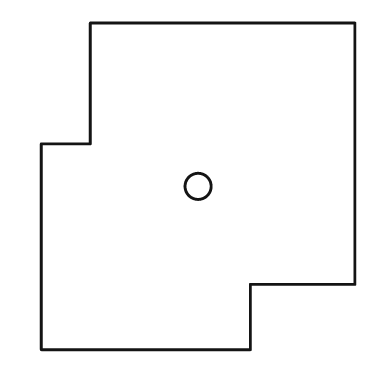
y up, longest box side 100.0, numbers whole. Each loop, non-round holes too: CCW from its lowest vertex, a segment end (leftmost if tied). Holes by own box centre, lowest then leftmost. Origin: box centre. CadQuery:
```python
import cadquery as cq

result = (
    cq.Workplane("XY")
    .moveTo(-48.0, -50.0)
    .lineTo(16.0, -50.0)
    .lineTo(16.0, -30.0)
    .lineTo(48.0, -30.0)
    .lineTo(48.0, 50.0)
    .lineTo(-33.0, 50.0)
    .lineTo(-33.0, 13.0)
    .lineTo(-48.0, 13.0)
    .close()
    .moveTo(0.0, 0.0)
    .circle(4.0)
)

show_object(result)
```